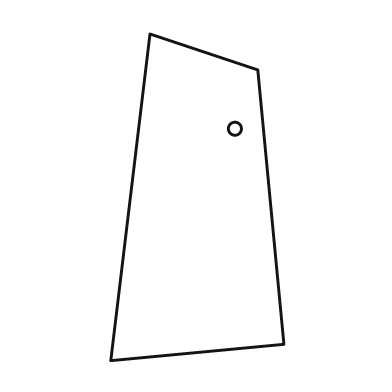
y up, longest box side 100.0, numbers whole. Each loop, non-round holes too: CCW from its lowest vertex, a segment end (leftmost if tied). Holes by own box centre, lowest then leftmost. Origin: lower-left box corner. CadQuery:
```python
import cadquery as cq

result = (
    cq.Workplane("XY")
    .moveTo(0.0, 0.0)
    .lineTo(53.0, 5.0)
    .lineTo(45.0, 89.0)
    .lineTo(12.0, 100.0)
    .close()
    .moveTo(38.0, 71.0)
    .circle(2.0)
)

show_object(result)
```